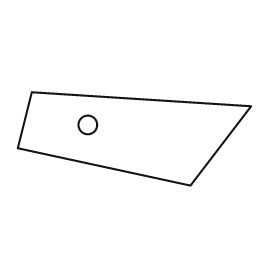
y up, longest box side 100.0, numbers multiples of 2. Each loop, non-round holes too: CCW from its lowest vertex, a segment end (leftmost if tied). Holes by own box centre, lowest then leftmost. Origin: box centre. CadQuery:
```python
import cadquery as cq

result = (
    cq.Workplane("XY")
    .moveTo(24.0, -20.0)
    .lineTo(50.0, 14.0)
    .lineTo(-44.0, 20.0)
    .lineTo(-50.0, -4.0)
    .close()
    .moveTo(-20.0, 6.0)
    .circle(4.0)
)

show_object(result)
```